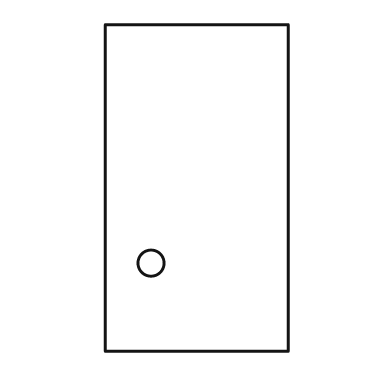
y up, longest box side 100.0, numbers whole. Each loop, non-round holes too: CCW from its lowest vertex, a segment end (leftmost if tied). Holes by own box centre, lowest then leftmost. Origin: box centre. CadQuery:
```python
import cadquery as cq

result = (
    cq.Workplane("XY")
    .moveTo(-28.0, -50.0)
    .lineTo(28.0, -50.0)
    .lineTo(28.0, 50.0)
    .lineTo(-28.0, 50.0)
    .close()
    .moveTo(-14.0, -23.0)
    .circle(4.0)
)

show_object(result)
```